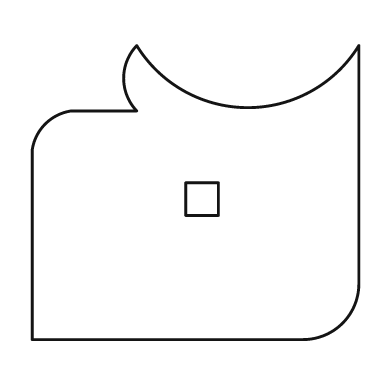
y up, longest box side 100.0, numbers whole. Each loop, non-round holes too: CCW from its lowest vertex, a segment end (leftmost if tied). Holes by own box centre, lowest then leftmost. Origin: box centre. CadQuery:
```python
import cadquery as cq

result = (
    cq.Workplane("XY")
    .moveTo(-50.0, -45.0)
    .lineTo(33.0, -45.0)
    .threePointArc((45.0, -40.0), (50.0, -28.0))
    .lineTo(50.0, 45.0)
    .threePointArc((16.0, 26.0), (-18.0, 45.0))
    .threePointArc((-22.0, 35.0), (-18.0, 25.0))
    .lineTo(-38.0, 25.0)
    .threePointArc((-46.0, 21.0), (-50.0, 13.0))
    .close()
    .moveTo(-3.0, -7.0)
    .lineTo(7.0, -7.0)
    .lineTo(7.0, 3.0)
    .lineTo(-3.0, 3.0)
    .close()
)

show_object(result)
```